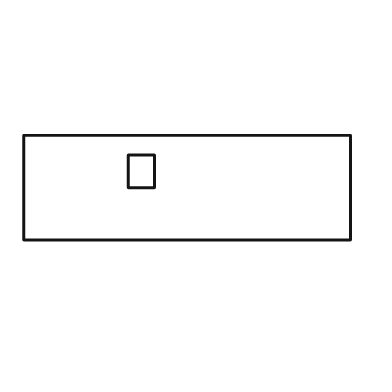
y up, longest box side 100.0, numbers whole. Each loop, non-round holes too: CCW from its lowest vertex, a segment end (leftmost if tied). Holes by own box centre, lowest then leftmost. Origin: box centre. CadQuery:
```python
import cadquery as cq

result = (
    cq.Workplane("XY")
    .moveTo(-50.0, -16.0)
    .lineTo(50.0, -16.0)
    .lineTo(50.0, 16.0)
    .lineTo(-50.0, 16.0)
    .close()
    .moveTo(-18.0, 0.0)
    .lineTo(-10.0, 0.0)
    .lineTo(-10.0, 10.0)
    .lineTo(-18.0, 10.0)
    .close()
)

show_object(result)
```